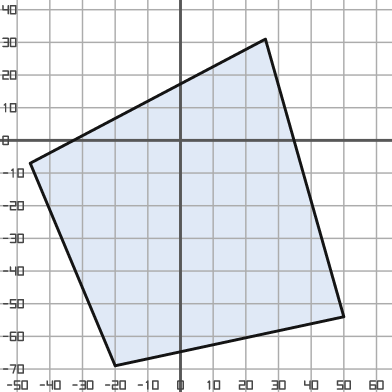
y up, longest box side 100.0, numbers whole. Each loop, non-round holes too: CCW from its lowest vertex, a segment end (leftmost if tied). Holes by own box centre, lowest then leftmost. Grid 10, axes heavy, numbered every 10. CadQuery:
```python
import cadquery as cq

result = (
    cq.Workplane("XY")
    .moveTo(-20.0, -69.0)
    .lineTo(50.0, -54.0)
    .lineTo(26.0, 31.0)
    .lineTo(-46.0, -7.0)
    .close()
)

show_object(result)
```